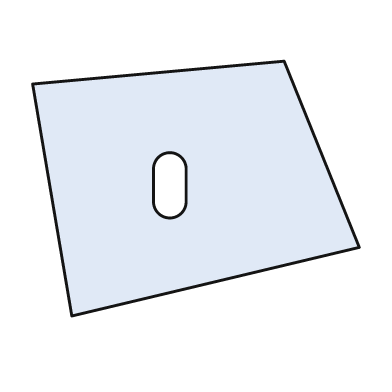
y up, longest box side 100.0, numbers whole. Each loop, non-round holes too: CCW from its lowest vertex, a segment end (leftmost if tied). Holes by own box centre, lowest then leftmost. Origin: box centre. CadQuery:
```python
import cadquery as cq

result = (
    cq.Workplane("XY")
    .moveTo(-38.0, -39.0)
    .lineTo(50.0, -18.0)
    .lineTo(27.0, 39.0)
    .lineTo(-50.0, 32.0)
    .close()
    .moveTo(-13.0, -4.0)
    .threePointArc((-8.0, -9.0), (-3.0, -4.0))
    .lineTo(-3.0, 6.0)
    .threePointArc((-8.0, 11.0), (-13.0, 6.0))
    .close()
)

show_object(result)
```